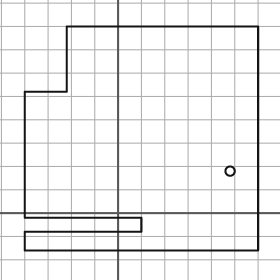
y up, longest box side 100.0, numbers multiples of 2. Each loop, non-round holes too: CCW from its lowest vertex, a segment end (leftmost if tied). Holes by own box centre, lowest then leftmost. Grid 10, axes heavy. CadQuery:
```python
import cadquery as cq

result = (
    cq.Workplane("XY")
    .moveTo(-40.0, -16.0)
    .lineTo(60.0, -16.0)
    .lineTo(60.0, 80.0)
    .lineTo(-22.0, 80.0)
    .lineTo(-22.0, 52.0)
    .lineTo(-40.0, 52.0)
    .lineTo(-40.0, -2.0)
    .lineTo(10.0, -2.0)
    .lineTo(10.0, -8.0)
    .lineTo(-40.0, -8.0)
    .close()
    .moveTo(48.0, 18.0)
    .circle(2.0)
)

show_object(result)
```